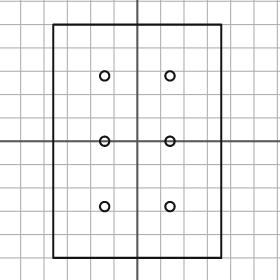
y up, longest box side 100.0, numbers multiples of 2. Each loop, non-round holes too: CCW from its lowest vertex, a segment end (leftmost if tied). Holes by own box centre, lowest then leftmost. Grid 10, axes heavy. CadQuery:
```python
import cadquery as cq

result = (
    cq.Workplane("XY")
    .moveTo(-36.0, -50.0)
    .lineTo(36.0, -50.0)
    .lineTo(36.0, 50.0)
    .lineTo(-36.0, 50.0)
    .close()
    .moveTo(-14.0, -28.0)
    .circle(2.0)
    .moveTo(14.0, -28.0)
    .circle(2.0)
    .moveTo(-14.0, 0.0)
    .circle(2.0)
    .moveTo(14.0, 0.0)
    .circle(2.0)
    .moveTo(-14.0, 28.0)
    .circle(2.0)
    .moveTo(14.0, 28.0)
    .circle(2.0)
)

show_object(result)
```